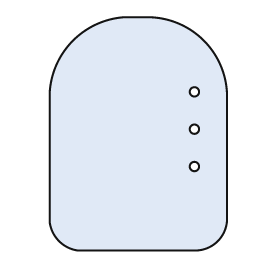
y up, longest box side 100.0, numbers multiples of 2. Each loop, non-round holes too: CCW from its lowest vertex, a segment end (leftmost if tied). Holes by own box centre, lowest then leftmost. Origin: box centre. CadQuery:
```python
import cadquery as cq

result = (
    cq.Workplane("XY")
    .moveTo(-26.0, -50.0)
    .lineTo(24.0, -50.0)
    .threePointArc((34.0, -46.0), (38.0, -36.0))
    .lineTo(38.0, 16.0)
    .threePointArc((28.0, 40.0), (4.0, 50.0))
    .lineTo(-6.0, 50.0)
    .threePointArc((-28.0, 40.0), (-38.0, 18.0))
    .lineTo(-38.0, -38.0)
    .threePointArc((-34.0, -46.0), (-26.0, -50.0))
    .close()
    .moveTo(24.0, -14.0)
    .circle(2.0)
    .moveTo(24.0, 2.0)
    .circle(2.0)
    .moveTo(24.0, 18.0)
    .circle(2.0)
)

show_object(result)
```